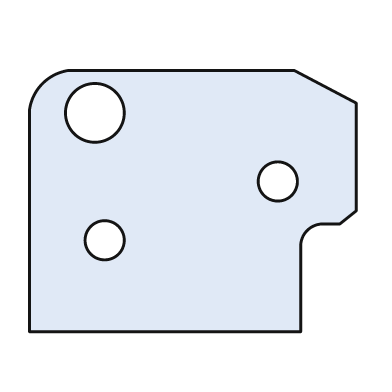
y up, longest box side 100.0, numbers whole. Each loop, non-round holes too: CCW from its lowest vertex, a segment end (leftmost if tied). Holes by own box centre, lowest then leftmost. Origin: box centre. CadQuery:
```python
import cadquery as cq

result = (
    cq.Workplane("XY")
    .moveTo(-50.0, -40.0)
    .lineTo(33.0, -40.0)
    .lineTo(33.0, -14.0)
    .threePointArc((35.0, -9.0), (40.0, -7.0))
    .lineTo(45.0, -7.0)
    .lineTo(50.0, -3.0)
    .lineTo(50.0, 30.0)
    .lineTo(31.0, 40.0)
    .lineTo(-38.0, 40.0)
    .threePointArc((-46.0, 36.0), (-50.0, 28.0))
    .close()
    .moveTo(-27.0, -12.0)
    .circle(6.0)
    .moveTo(26.0, 6.0)
    .circle(6.0)
    .moveTo(-30.0, 27.0)
    .circle(9.0)
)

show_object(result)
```